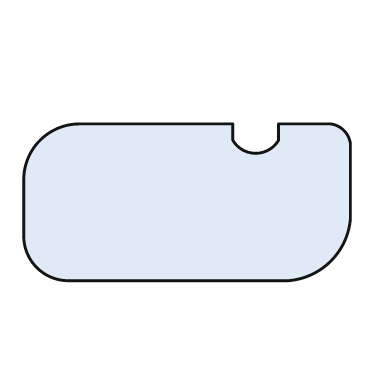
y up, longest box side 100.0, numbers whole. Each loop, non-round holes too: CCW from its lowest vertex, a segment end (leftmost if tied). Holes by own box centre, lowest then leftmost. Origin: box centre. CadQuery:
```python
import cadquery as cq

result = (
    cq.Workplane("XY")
    .moveTo(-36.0, -24.0)
    .lineTo(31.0, -24.0)
    .threePointArc((44.0, -18.0), (50.0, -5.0))
    .lineTo(50.0, 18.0)
    .threePointArc((48.0, 22.0), (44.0, 24.0))
    .lineTo(28.0, 24.0)
    .lineTo(28.0, 19.0)
    .threePointArc((21.0, 15.0), (14.0, 19.0))
    .lineTo(14.0, 24.0)
    .lineTo(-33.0, 24.0)
    .threePointArc((-45.0, 19.0), (-50.0, 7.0))
    .lineTo(-50.0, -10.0)
    .threePointArc((-46.0, -20.0), (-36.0, -24.0))
    .close()
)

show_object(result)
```